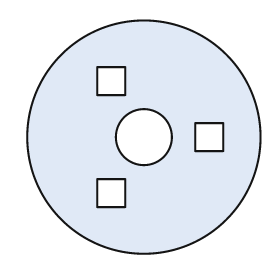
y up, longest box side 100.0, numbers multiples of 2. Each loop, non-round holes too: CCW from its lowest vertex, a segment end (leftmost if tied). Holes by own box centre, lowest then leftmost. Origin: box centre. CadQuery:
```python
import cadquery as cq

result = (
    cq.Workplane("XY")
    .moveTo(0.0, 0.0)
    .circle(50.0)
    .moveTo(-20.0, -30.0)
    .lineTo(-8.0, -30.0)
    .lineTo(-8.0, -18.0)
    .lineTo(-20.0, -18.0)
    .close()
    .moveTo(0.0, 0.0)
    .circle(12.0)
    .moveTo(22.0, -6.0)
    .lineTo(34.0, -6.0)
    .lineTo(34.0, 6.0)
    .lineTo(22.0, 6.0)
    .close()
    .moveTo(-20.0, 18.0)
    .lineTo(-8.0, 18.0)
    .lineTo(-8.0, 30.0)
    .lineTo(-20.0, 30.0)
    .close()
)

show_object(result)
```